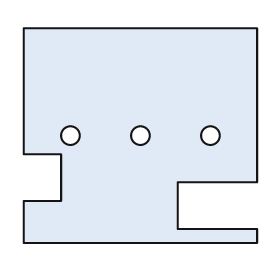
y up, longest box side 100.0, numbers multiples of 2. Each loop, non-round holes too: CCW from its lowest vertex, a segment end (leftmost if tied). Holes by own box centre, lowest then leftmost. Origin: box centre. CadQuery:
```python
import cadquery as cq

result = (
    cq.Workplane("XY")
    .moveTo(-50.0, -46.0)
    .lineTo(50.0, -46.0)
    .lineTo(50.0, -40.0)
    .lineTo(16.0, -40.0)
    .lineTo(16.0, -20.0)
    .lineTo(50.0, -20.0)
    .lineTo(50.0, 46.0)
    .lineTo(-50.0, 46.0)
    .lineTo(-50.0, -8.0)
    .lineTo(-34.0, -8.0)
    .lineTo(-34.0, -28.0)
    .lineTo(-50.0, -28.0)
    .close()
    .moveTo(-30.0, 0.0)
    .circle(4.0)
    .moveTo(0.0, 0.0)
    .circle(4.0)
    .moveTo(30.0, 0.0)
    .circle(4.0)
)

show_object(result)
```